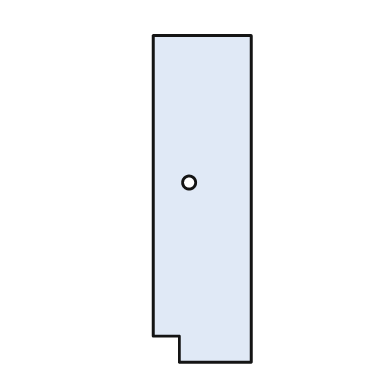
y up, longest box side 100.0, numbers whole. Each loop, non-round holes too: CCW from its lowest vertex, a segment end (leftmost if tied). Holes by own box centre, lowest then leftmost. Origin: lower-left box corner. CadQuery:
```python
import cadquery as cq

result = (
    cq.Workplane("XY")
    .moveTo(8.0, 0.0)
    .lineTo(30.0, 0.0)
    .lineTo(30.0, 100.0)
    .lineTo(0.0, 100.0)
    .lineTo(0.0, 8.0)
    .lineTo(8.0, 8.0)
    .close()
    .moveTo(11.0, 55.0)
    .circle(2.0)
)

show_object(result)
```